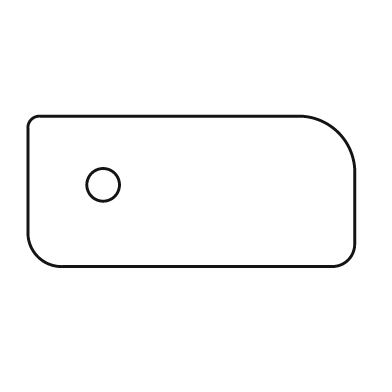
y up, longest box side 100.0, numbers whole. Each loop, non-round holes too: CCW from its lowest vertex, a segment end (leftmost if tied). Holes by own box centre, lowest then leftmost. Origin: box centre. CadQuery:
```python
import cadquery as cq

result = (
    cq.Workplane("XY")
    .moveTo(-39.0, -23.0)
    .lineTo(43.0, -23.0)
    .threePointArc((48.0, -21.0), (50.0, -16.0))
    .lineTo(50.0, 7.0)
    .threePointArc((45.0, 18.0), (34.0, 23.0))
    .lineTo(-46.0, 23.0)
    .threePointArc((-49.0, 22.0), (-50.0, 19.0))
    .lineTo(-50.0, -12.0)
    .threePointArc((-47.0, -20.0), (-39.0, -23.0))
    .close()
    .moveTo(-27.0, 2.0)
    .circle(5.0)
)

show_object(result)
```